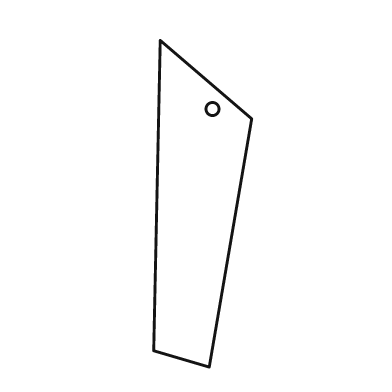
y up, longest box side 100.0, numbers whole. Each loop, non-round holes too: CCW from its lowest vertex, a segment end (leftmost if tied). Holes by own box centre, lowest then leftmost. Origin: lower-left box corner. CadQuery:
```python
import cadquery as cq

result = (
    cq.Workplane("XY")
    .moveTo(17.0, 0.0)
    .lineTo(30.0, 76.0)
    .lineTo(2.0, 100.0)
    .lineTo(0.0, 5.0)
    .close()
    .moveTo(18.0, 79.0)
    .circle(2.0)
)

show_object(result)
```